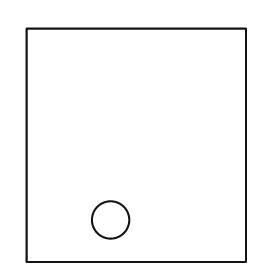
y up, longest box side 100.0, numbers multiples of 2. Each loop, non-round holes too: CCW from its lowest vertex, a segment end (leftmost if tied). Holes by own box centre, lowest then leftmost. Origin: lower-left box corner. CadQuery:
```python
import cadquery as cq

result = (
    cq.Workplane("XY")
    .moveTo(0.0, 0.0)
    .lineTo(94.0, 0.0)
    .lineTo(94.0, 100.0)
    .lineTo(0.0, 100.0)
    .close()
    .moveTo(36.0, 18.0)
    .circle(8.0)
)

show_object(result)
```